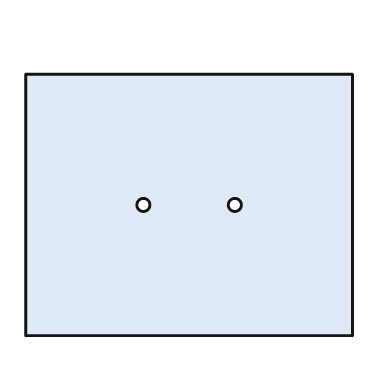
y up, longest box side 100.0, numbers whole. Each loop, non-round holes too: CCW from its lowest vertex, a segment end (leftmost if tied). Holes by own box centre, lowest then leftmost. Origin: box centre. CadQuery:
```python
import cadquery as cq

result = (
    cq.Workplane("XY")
    .moveTo(-50.0, -40.0)
    .lineTo(50.0, -40.0)
    .lineTo(50.0, 40.0)
    .lineTo(-50.0, 40.0)
    .close()
    .moveTo(-14.0, 0.0)
    .circle(2.0)
    .moveTo(14.0, 0.0)
    .circle(2.0)
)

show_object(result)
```